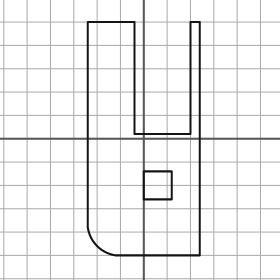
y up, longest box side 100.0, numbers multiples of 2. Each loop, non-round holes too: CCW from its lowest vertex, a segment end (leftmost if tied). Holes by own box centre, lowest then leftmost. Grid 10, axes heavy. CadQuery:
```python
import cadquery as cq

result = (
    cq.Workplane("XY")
    .moveTo(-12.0, -50.0)
    .lineTo(24.0, -50.0)
    .lineTo(24.0, 50.0)
    .lineTo(20.0, 50.0)
    .lineTo(20.0, 2.0)
    .lineTo(-4.0, 2.0)
    .lineTo(-4.0, 50.0)
    .lineTo(-24.0, 50.0)
    .lineTo(-24.0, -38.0)
    .threePointArc((-20.0, -46.0), (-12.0, -50.0))
    .close()
    .moveTo(0.0, -26.0)
    .lineTo(12.0, -26.0)
    .lineTo(12.0, -14.0)
    .lineTo(0.0, -14.0)
    .close()
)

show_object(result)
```